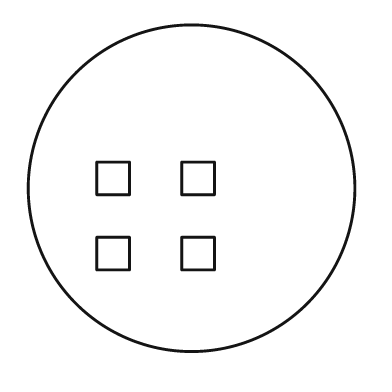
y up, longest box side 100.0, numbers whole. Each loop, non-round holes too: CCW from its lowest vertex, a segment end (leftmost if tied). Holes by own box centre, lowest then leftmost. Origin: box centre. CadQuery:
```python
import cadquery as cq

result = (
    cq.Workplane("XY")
    .moveTo(0.0, 0.0)
    .circle(50.0)
    .moveTo(-29.0, -25.0)
    .lineTo(-19.0, -25.0)
    .lineTo(-19.0, -15.0)
    .lineTo(-29.0, -15.0)
    .close()
    .moveTo(-3.0, -25.0)
    .lineTo(7.0, -25.0)
    .lineTo(7.0, -15.0)
    .lineTo(-3.0, -15.0)
    .close()
    .moveTo(-29.0, -2.0)
    .lineTo(-19.0, -2.0)
    .lineTo(-19.0, 8.0)
    .lineTo(-29.0, 8.0)
    .close()
    .moveTo(-3.0, -2.0)
    .lineTo(7.0, -2.0)
    .lineTo(7.0, 8.0)
    .lineTo(-3.0, 8.0)
    .close()
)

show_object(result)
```